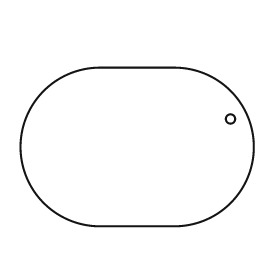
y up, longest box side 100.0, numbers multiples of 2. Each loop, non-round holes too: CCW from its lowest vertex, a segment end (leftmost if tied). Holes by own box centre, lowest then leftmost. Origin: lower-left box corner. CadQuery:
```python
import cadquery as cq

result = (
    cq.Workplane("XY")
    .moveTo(34.0, 0.0)
    .lineTo(66.0, 0.0)
    .threePointArc((100.0, 34.0), (66.0, 68.0))
    .lineTo(34.0, 68.0)
    .threePointArc((0.0, 34.0), (34.0, 0.0))
    .close()
    .moveTo(90.0, 46.0)
    .circle(2.0)
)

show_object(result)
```